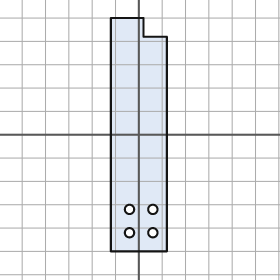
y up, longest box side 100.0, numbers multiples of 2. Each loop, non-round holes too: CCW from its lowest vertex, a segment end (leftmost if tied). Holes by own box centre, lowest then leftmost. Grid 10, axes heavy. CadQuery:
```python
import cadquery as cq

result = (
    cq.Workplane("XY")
    .moveTo(-12.0, -50.0)
    .lineTo(12.0, -50.0)
    .lineTo(12.0, 42.0)
    .lineTo(2.0, 42.0)
    .lineTo(2.0, 50.0)
    .lineTo(-12.0, 50.0)
    .close()
    .moveTo(-4.0, -42.0)
    .circle(2.0)
    .moveTo(6.0, -42.0)
    .circle(2.0)
    .moveTo(-4.0, -32.0)
    .circle(2.0)
    .moveTo(6.0, -32.0)
    .circle(2.0)
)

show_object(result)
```